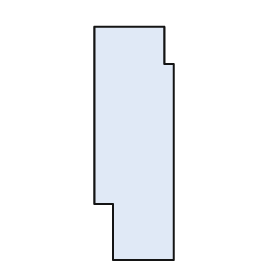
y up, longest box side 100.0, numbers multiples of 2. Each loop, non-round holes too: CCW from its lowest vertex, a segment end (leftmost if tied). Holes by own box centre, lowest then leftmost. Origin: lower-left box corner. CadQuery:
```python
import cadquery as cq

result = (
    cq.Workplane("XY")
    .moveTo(8.0, 0.0)
    .lineTo(34.0, 0.0)
    .lineTo(34.0, 84.0)
    .lineTo(30.0, 84.0)
    .lineTo(30.0, 100.0)
    .lineTo(0.0, 100.0)
    .lineTo(0.0, 24.0)
    .lineTo(8.0, 24.0)
    .close()
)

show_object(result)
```